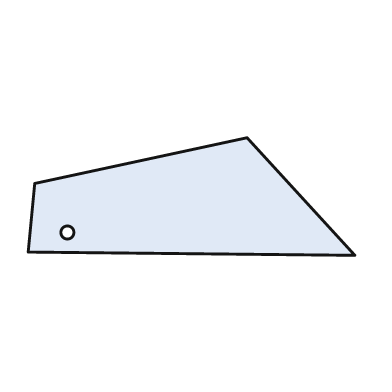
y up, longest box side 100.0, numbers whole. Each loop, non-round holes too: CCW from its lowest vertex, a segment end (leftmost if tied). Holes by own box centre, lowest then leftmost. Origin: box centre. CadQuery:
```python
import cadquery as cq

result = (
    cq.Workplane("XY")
    .moveTo(50.0, -18.0)
    .lineTo(17.0, 18.0)
    .lineTo(-48.0, 4.0)
    .lineTo(-50.0, -17.0)
    .close()
    .moveTo(-38.0, -11.0)
    .circle(2.0)
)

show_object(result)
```